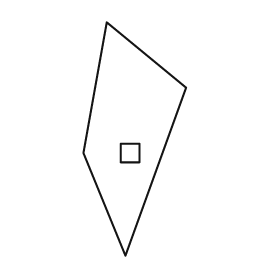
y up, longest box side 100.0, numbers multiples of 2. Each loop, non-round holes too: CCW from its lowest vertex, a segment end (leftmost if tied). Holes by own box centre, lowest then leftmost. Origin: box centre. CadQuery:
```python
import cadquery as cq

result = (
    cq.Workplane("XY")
    .moveTo(-4.0, -50.0)
    .lineTo(22.0, 22.0)
    .lineTo(-12.0, 50.0)
    .lineTo(-22.0, -6.0)
    .close()
    .moveTo(-6.0, -10.0)
    .lineTo(2.0, -10.0)
    .lineTo(2.0, -2.0)
    .lineTo(-6.0, -2.0)
    .close()
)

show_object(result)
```